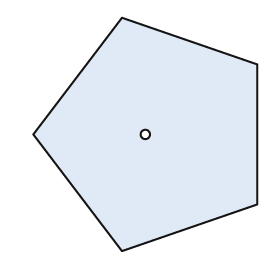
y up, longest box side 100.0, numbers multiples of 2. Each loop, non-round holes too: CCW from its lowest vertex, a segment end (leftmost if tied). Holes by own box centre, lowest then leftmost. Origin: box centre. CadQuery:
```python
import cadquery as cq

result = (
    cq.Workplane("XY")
    .moveTo(-10.0, -50.0)
    .lineTo(48.0, -30.0)
    .lineTo(48.0, 30.0)
    .lineTo(-10.0, 50.0)
    .lineTo(-48.0, 0.0)
    .close()
    .moveTo(0.0, 0.0)
    .circle(2.0)
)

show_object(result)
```